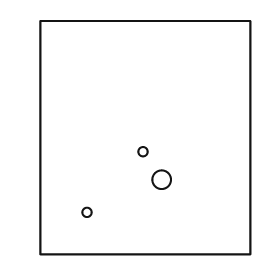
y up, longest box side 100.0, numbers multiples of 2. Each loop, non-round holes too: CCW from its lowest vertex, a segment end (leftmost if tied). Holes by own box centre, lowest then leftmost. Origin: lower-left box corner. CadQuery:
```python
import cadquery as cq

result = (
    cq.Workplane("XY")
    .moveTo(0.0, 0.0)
    .lineTo(90.0, 0.0)
    .lineTo(90.0, 100.0)
    .lineTo(0.0, 100.0)
    .close()
    .moveTo(20.0, 18.0)
    .circle(2.0)
    .moveTo(52.0, 32.0)
    .circle(4.0)
    .moveTo(44.0, 44.0)
    .circle(2.0)
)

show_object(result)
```